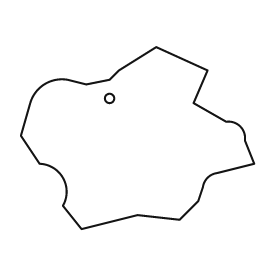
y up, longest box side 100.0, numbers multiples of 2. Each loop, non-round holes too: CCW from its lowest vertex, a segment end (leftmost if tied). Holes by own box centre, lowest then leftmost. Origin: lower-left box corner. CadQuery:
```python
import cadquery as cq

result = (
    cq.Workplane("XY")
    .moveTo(26.0, 0.0)
    .lineTo(50.0, 6.0)
    .lineTo(68.0, 4.0)
    .lineTo(76.0, 12.0)
    .lineTo(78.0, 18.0)
    .threePointArc((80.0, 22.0), (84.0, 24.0))
    .lineTo(100.0, 28.0)
    .lineTo(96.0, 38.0)
    .threePointArc((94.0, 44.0), (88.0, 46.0))
    .lineTo(74.0, 54.0)
    .lineTo(80.0, 68.0)
    .lineTo(58.0, 78.0)
    .lineTo(42.0, 68.0)
    .lineTo(38.0, 64.0)
    .lineTo(28.0, 62.0)
    .lineTo(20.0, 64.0)
    .threePointArc((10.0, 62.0), (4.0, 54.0))
    .lineTo(0.0, 40.0)
    .lineTo(8.0, 28.0)
    .threePointArc((18.0, 22.0), (18.0, 10.0))
    .close()
    .moveTo(38.0, 56.0)
    .circle(2.0)
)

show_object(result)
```